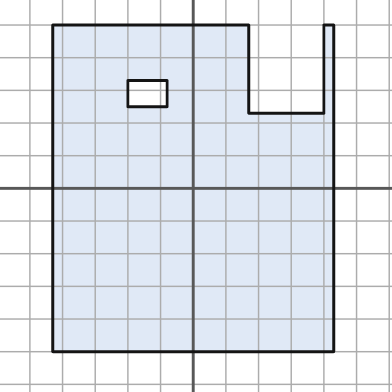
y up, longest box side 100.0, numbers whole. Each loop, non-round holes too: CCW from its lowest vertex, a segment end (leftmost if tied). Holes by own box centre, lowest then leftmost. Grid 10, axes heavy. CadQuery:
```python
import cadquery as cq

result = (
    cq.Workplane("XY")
    .moveTo(-43.0, -50.0)
    .lineTo(43.0, -50.0)
    .lineTo(43.0, 50.0)
    .lineTo(40.0, 50.0)
    .lineTo(40.0, 23.0)
    .lineTo(17.0, 23.0)
    .lineTo(17.0, 50.0)
    .lineTo(-43.0, 50.0)
    .close()
    .moveTo(-20.0, 25.0)
    .lineTo(-8.0, 25.0)
    .lineTo(-8.0, 33.0)
    .lineTo(-20.0, 33.0)
    .close()
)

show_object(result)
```